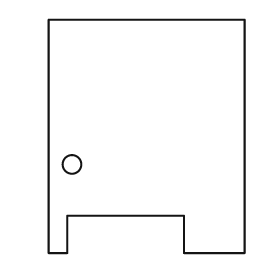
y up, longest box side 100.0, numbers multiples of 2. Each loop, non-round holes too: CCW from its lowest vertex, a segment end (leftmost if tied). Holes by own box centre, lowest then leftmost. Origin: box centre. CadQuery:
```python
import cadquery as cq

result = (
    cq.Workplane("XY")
    .moveTo(-42.0, -50.0)
    .lineTo(-34.0, -50.0)
    .lineTo(-34.0, -34.0)
    .lineTo(16.0, -34.0)
    .lineTo(16.0, -50.0)
    .lineTo(42.0, -50.0)
    .lineTo(42.0, 50.0)
    .lineTo(-42.0, 50.0)
    .close()
    .moveTo(-32.0, -12.0)
    .circle(4.0)
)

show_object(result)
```